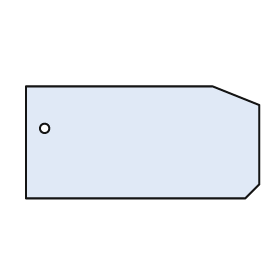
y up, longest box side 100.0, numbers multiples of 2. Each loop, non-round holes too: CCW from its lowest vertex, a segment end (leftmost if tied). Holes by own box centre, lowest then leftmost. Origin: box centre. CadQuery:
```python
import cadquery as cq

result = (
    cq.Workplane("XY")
    .moveTo(-50.0, -24.0)
    .lineTo(44.0, -24.0)
    .lineTo(50.0, -18.0)
    .lineTo(50.0, 16.0)
    .lineTo(30.0, 24.0)
    .lineTo(-50.0, 24.0)
    .close()
    .moveTo(-42.0, 6.0)
    .circle(2.0)
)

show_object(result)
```